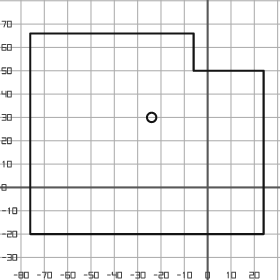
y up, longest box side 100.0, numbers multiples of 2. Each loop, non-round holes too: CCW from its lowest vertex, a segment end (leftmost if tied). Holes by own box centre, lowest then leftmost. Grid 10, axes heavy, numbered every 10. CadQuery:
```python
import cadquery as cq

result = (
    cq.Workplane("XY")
    .moveTo(-76.0, -20.0)
    .lineTo(24.0, -20.0)
    .lineTo(24.0, 50.0)
    .lineTo(-6.0, 50.0)
    .lineTo(-6.0, 66.0)
    .lineTo(-76.0, 66.0)
    .close()
    .moveTo(-24.0, 30.0)
    .circle(2.0)
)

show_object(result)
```